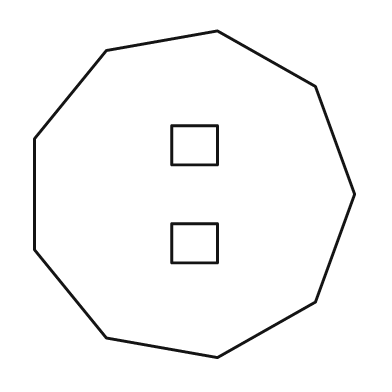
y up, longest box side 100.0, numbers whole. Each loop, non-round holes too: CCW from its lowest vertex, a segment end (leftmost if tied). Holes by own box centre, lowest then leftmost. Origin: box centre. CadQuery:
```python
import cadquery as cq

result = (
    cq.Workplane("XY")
    .moveTo(7.0, -50.0)
    .lineTo(37.0, -33.0)
    .lineTo(49.0, 0.0)
    .lineTo(37.0, 33.0)
    .lineTo(7.0, 50.0)
    .lineTo(-27.0, 44.0)
    .lineTo(-49.0, 17.0)
    .lineTo(-49.0, -17.0)
    .lineTo(-27.0, -44.0)
    .close()
    .moveTo(-7.0, -21.0)
    .lineTo(7.0, -21.0)
    .lineTo(7.0, -9.0)
    .lineTo(-7.0, -9.0)
    .close()
    .moveTo(-7.0, 9.0)
    .lineTo(7.0, 9.0)
    .lineTo(7.0, 21.0)
    .lineTo(-7.0, 21.0)
    .close()
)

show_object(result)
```